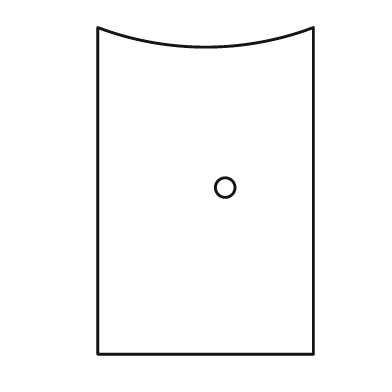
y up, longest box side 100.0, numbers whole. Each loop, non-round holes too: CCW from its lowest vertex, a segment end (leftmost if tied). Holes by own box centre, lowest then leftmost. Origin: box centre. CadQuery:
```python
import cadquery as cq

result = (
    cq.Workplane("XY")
    .moveTo(-33.0, -50.0)
    .lineTo(33.0, -50.0)
    .lineTo(33.0, 50.0)
    .threePointArc((0.0, 44.0), (-33.0, 50.0))
    .close()
    .moveTo(6.0, 1.0)
    .circle(3.0)
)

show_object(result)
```